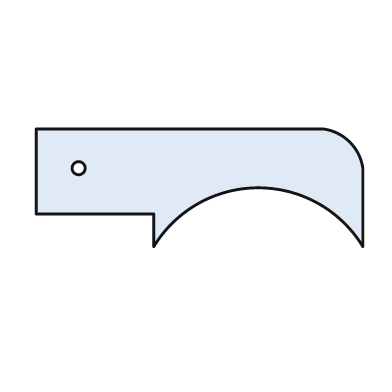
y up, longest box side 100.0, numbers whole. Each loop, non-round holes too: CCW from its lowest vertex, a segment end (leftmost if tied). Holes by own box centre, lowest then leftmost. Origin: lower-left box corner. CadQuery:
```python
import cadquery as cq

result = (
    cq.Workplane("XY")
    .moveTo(36.0, 0.0)
    .threePointArc((68.0, 18.0), (100.0, 0.0))
    .lineTo(100.0, 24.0)
    .threePointArc((96.0, 32.0), (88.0, 36.0))
    .lineTo(0.0, 36.0)
    .lineTo(0.0, 10.0)
    .lineTo(36.0, 10.0)
    .close()
    .moveTo(13.0, 24.0)
    .circle(2.0)
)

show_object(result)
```